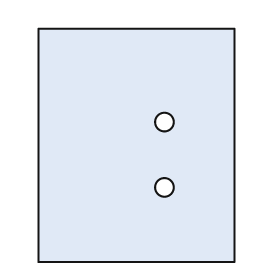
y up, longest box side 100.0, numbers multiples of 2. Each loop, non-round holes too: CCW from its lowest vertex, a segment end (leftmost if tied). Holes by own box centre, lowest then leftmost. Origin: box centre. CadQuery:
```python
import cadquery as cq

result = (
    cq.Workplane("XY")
    .moveTo(-42.0, -50.0)
    .lineTo(42.0, -50.0)
    .lineTo(42.0, 50.0)
    .lineTo(-42.0, 50.0)
    .close()
    .moveTo(12.0, -18.0)
    .circle(4.0)
    .moveTo(12.0, 10.0)
    .circle(4.0)
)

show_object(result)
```